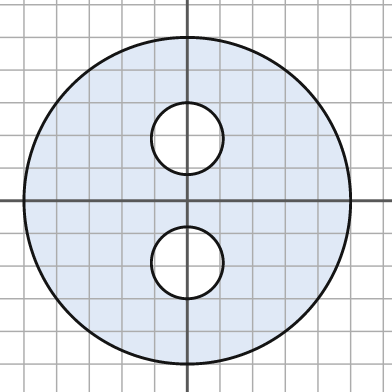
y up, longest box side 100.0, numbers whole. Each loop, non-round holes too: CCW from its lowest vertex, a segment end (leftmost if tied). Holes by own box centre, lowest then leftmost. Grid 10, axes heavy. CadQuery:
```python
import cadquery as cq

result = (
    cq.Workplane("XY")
    .moveTo(0.0, 0.0)
    .circle(50.0)
    .moveTo(0.0, -19.0)
    .circle(11.0)
    .moveTo(0.0, 19.0)
    .circle(11.0)
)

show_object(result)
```